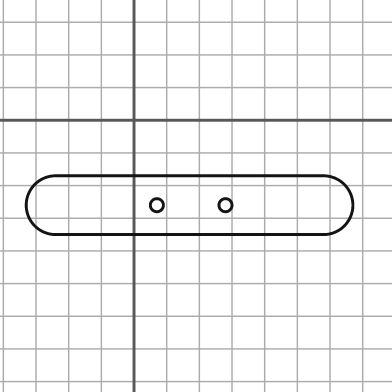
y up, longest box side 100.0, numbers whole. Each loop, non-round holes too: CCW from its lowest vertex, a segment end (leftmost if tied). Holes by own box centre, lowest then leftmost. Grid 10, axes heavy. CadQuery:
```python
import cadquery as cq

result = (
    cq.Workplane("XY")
    .moveTo(-24.0, -35.0)
    .lineTo(58.0, -35.0)
    .threePointArc((67.0, -26.0), (58.0, -17.0))
    .lineTo(-24.0, -17.0)
    .threePointArc((-33.0, -26.0), (-24.0, -35.0))
    .close()
    .moveTo(7.0, -26.0)
    .circle(2.0)
    .moveTo(28.0, -26.0)
    .circle(2.0)
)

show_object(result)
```